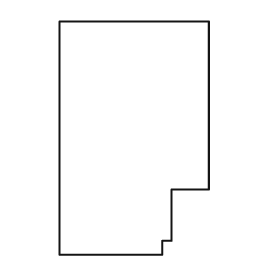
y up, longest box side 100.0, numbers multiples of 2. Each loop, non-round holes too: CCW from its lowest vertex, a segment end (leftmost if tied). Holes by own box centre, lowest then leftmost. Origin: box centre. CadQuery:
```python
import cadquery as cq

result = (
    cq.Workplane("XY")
    .moveTo(-32.0, -50.0)
    .lineTo(12.0, -50.0)
    .lineTo(12.0, -44.0)
    .lineTo(16.0, -44.0)
    .lineTo(16.0, -22.0)
    .lineTo(32.0, -22.0)
    .lineTo(32.0, 50.0)
    .lineTo(-32.0, 50.0)
    .close()
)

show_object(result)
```